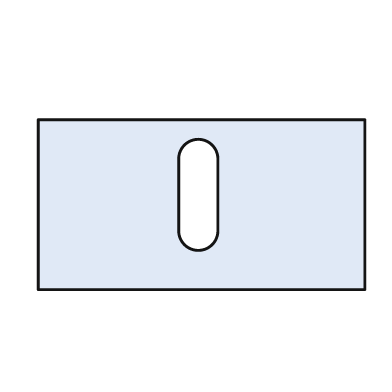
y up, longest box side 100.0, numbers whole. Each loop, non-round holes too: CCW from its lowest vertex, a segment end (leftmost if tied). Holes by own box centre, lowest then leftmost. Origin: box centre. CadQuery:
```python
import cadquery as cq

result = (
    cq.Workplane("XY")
    .moveTo(-50.0, -26.0)
    .lineTo(50.0, -26.0)
    .lineTo(50.0, 26.0)
    .lineTo(-50.0, 26.0)
    .close()
    .moveTo(-7.0, -8.0)
    .threePointArc((-1.0, -14.0), (5.0, -8.0))
    .lineTo(5.0, 14.0)
    .threePointArc((-1.0, 20.0), (-7.0, 14.0))
    .close()
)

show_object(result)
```